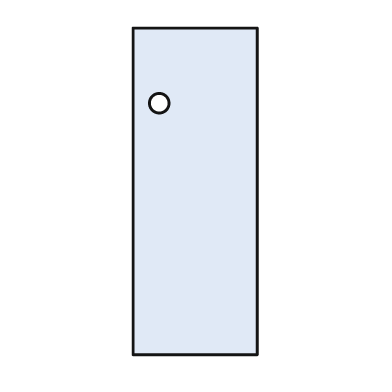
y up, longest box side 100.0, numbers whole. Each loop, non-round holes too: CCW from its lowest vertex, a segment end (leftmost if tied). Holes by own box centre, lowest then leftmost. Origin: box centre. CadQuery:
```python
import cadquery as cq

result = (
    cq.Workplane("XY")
    .moveTo(-19.0, -50.0)
    .lineTo(19.0, -50.0)
    .lineTo(19.0, 50.0)
    .lineTo(-19.0, 50.0)
    .close()
    .moveTo(-11.0, 27.0)
    .circle(3.0)
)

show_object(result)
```